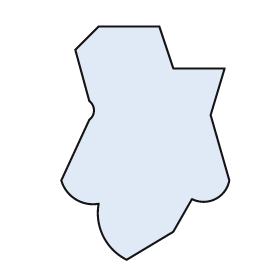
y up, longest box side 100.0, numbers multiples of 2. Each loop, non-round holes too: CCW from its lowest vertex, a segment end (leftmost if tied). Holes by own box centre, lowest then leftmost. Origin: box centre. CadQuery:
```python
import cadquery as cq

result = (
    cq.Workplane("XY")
    .moveTo(-8.0, -50.0)
    .lineTo(12.0, -38.0)
    .lineTo(20.0, -24.0)
    .threePointArc((30.0, -24.0), (36.0, -16.0))
    .lineTo(28.0, 12.0)
    .lineTo(34.0, 32.0)
    .lineTo(12.0, 32.0)
    .lineTo(6.0, 50.0)
    .lineTo(-20.0, 50.0)
    .lineTo(-30.0, 40.0)
    .lineTo(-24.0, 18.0)
    .threePointArc((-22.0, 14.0), (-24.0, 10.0))
    .lineTo(-36.0, -16.0)
    .threePointArc((-30.0, -24.0), (-20.0, -26.0))
    .threePointArc((-18.0, -40.0), (-8.0, -50.0))
    .close()
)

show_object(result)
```